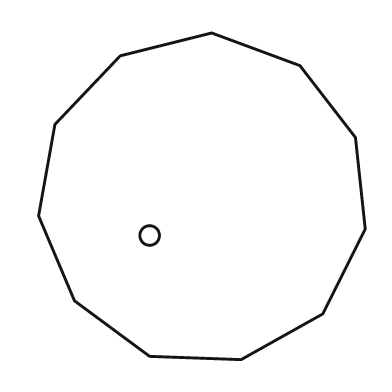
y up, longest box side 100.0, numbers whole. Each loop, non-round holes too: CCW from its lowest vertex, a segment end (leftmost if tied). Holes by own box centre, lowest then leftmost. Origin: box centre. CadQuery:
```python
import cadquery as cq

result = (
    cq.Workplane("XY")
    .moveTo(12.0, -50.0)
    .lineTo(37.0, -36.0)
    .lineTo(50.0, -10.0)
    .lineTo(47.0, 18.0)
    .lineTo(30.0, 40.0)
    .lineTo(3.0, 50.0)
    .lineTo(-25.0, 43.0)
    .lineTo(-45.0, 22.0)
    .lineTo(-50.0, -6.0)
    .lineTo(-39.0, -32.0)
    .lineTo(-16.0, -49.0)
    .close()
    .moveTo(-16.0, -12.0)
    .circle(3.0)
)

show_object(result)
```